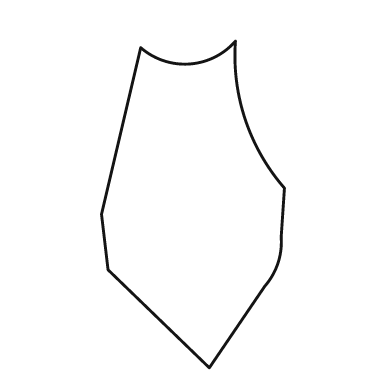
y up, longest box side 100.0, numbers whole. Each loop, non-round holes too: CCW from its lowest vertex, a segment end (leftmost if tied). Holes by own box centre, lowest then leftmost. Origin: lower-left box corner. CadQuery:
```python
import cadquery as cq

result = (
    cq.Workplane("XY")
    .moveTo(33.0, 0.0)
    .lineTo(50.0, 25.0)
    .threePointArc((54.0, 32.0), (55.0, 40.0))
    .lineTo(56.0, 55.0)
    .threePointArc((44.0, 76.0), (41.0, 100.0))
    .threePointArc((27.0, 93.0), (12.0, 98.0))
    .lineTo(0.0, 47.0)
    .lineTo(2.0, 30.0)
    .close()
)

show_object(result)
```